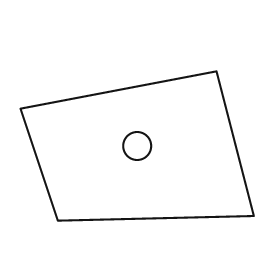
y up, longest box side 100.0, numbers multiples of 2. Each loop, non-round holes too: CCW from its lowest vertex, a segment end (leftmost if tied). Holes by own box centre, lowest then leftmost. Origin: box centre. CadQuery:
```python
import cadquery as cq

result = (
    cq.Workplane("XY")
    .moveTo(-34.0, -32.0)
    .lineTo(50.0, -30.0)
    .lineTo(34.0, 32.0)
    .lineTo(-50.0, 16.0)
    .close()
    .moveTo(0.0, 0.0)
    .circle(6.0)
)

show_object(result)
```